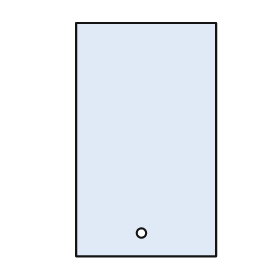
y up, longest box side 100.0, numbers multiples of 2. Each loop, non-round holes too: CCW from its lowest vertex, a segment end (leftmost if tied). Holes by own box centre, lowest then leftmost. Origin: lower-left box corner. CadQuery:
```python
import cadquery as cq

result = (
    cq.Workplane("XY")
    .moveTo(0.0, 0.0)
    .lineTo(60.0, 0.0)
    .lineTo(60.0, 100.0)
    .lineTo(0.0, 100.0)
    .close()
    .moveTo(28.0, 10.0)
    .circle(2.0)
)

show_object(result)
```